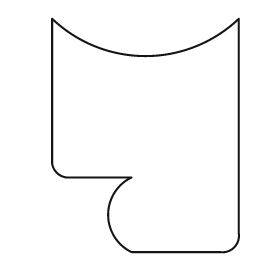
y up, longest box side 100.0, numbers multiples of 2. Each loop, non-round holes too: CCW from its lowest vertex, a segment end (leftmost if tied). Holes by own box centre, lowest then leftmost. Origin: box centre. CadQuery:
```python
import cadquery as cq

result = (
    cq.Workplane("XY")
    .moveTo(-6.0, -50.0)
    .lineTo(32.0, -50.0)
    .threePointArc((38.0, -48.0), (40.0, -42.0))
    .lineTo(40.0, 50.0)
    .threePointArc((0.0, 34.0), (-40.0, 50.0))
    .lineTo(-40.0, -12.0)
    .threePointArc((-38.0, -16.0), (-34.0, -18.0))
    .lineTo(-6.0, -18.0)
    .threePointArc((-16.0, -34.0), (-6.0, -50.0))
    .close()
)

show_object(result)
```